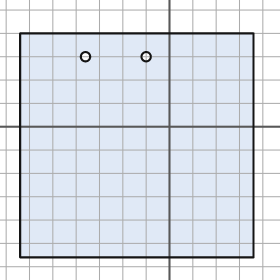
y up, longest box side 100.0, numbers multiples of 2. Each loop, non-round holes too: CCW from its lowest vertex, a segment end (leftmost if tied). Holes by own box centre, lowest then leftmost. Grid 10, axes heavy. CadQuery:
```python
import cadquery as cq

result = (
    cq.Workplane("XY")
    .moveTo(-64.0, -56.0)
    .lineTo(36.0, -56.0)
    .lineTo(36.0, 40.0)
    .lineTo(-64.0, 40.0)
    .close()
    .moveTo(-36.0, 30.0)
    .circle(2.0)
    .moveTo(-10.0, 30.0)
    .circle(2.0)
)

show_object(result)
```